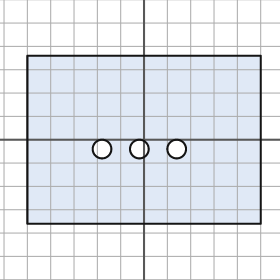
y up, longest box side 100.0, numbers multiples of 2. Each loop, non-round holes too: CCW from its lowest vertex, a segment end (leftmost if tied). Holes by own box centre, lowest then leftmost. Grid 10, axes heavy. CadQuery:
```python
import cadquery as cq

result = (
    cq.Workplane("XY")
    .moveTo(-50.0, -36.0)
    .lineTo(50.0, -36.0)
    .lineTo(50.0, 36.0)
    .lineTo(-50.0, 36.0)
    .close()
    .moveTo(-18.0, -4.0)
    .circle(4.0)
    .moveTo(-2.0, -4.0)
    .circle(4.0)
    .moveTo(14.0, -4.0)
    .circle(4.0)
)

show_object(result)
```